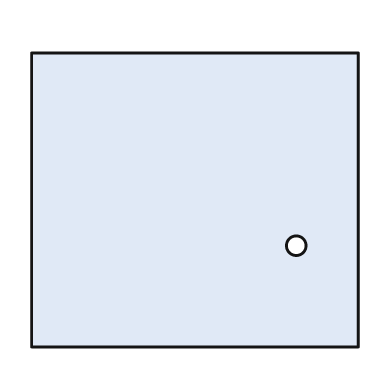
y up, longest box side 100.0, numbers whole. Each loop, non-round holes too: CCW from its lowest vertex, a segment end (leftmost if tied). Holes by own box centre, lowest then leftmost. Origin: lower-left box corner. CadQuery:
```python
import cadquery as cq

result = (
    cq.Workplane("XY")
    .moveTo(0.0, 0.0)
    .lineTo(100.0, 0.0)
    .lineTo(100.0, 90.0)
    .lineTo(0.0, 90.0)
    .close()
    .moveTo(81.0, 31.0)
    .circle(3.0)
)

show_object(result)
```